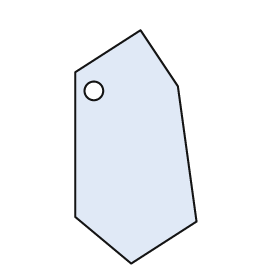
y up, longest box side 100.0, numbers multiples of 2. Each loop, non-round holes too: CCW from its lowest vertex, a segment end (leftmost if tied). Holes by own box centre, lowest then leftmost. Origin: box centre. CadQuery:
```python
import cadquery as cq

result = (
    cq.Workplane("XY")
    .moveTo(-2.0, -50.0)
    .lineTo(26.0, -32.0)
    .lineTo(18.0, 26.0)
    .lineTo(2.0, 50.0)
    .lineTo(-26.0, 32.0)
    .lineTo(-26.0, -30.0)
    .close()
    .moveTo(-18.0, 24.0)
    .circle(4.0)
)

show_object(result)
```